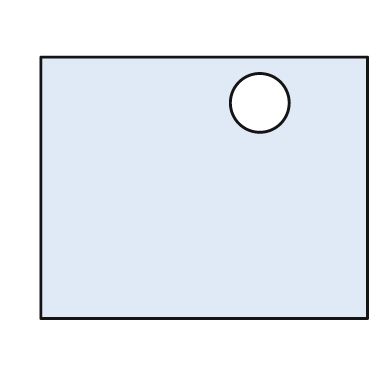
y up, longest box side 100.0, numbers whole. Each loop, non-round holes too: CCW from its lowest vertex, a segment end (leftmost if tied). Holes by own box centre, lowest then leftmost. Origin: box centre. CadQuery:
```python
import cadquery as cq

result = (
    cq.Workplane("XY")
    .moveTo(-50.0, -40.0)
    .lineTo(50.0, -40.0)
    .lineTo(50.0, 40.0)
    .lineTo(-50.0, 40.0)
    .close()
    .moveTo(17.0, 26.0)
    .circle(9.0)
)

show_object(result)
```